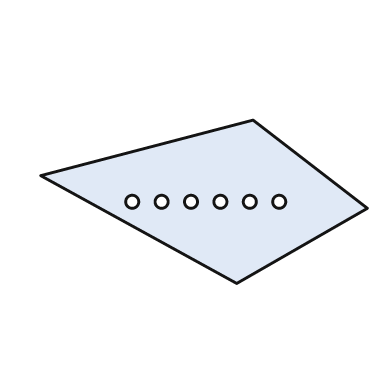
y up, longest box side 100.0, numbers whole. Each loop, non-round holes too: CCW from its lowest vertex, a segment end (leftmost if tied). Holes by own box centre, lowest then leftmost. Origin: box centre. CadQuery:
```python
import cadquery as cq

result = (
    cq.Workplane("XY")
    .moveTo(10.0, -25.0)
    .lineTo(50.0, -2.0)
    .lineTo(15.0, 25.0)
    .lineTo(-50.0, 8.0)
    .close()
    .moveTo(-22.0, 0.0)
    .circle(2.0)
    .moveTo(-13.0, 0.0)
    .circle(2.0)
    .moveTo(-4.0, 0.0)
    .circle(2.0)
    .moveTo(5.0, 0.0)
    .circle(2.0)
    .moveTo(14.0, 0.0)
    .circle(2.0)
    .moveTo(23.0, 0.0)
    .circle(2.0)
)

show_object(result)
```